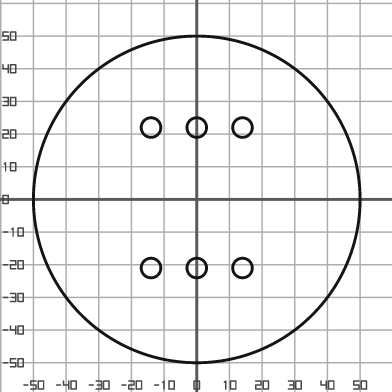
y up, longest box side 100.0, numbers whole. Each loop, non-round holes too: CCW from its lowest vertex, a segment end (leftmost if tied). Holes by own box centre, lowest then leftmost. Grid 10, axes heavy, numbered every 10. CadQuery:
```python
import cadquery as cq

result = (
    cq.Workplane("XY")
    .moveTo(0.0, 0.0)
    .circle(50.0)
    .moveTo(-14.0, -21.0)
    .circle(3.0)
    .moveTo(0.0, -21.0)
    .circle(3.0)
    .moveTo(14.0, -21.0)
    .circle(3.0)
    .moveTo(-14.0, 22.0)
    .circle(3.0)
    .moveTo(0.0, 22.0)
    .circle(3.0)
    .moveTo(14.0, 22.0)
    .circle(3.0)
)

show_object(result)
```